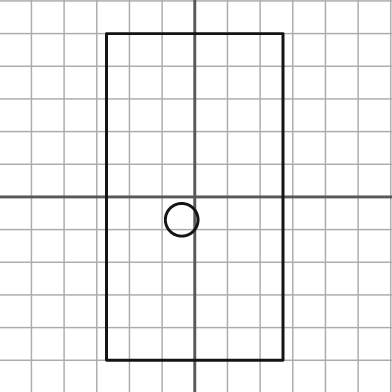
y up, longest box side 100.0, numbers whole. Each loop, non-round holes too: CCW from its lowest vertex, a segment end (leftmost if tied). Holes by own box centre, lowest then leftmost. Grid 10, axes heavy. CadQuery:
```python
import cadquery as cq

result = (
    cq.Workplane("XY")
    .moveTo(-27.0, -50.0)
    .lineTo(27.0, -50.0)
    .lineTo(27.0, 50.0)
    .lineTo(-27.0, 50.0)
    .close()
    .moveTo(-4.0, -7.0)
    .circle(5.0)
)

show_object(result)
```